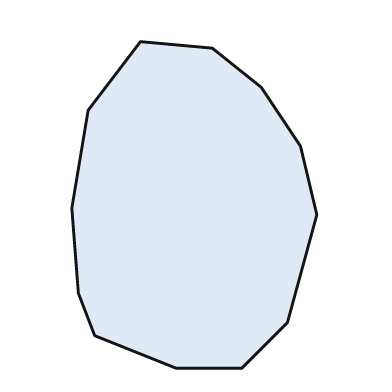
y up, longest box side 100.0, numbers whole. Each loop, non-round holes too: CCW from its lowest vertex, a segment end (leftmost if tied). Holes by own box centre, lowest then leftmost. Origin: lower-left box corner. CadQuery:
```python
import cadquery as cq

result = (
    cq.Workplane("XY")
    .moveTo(32.0, 0.0)
    .lineTo(52.0, 0.0)
    .lineTo(66.0, 14.0)
    .lineTo(75.0, 47.0)
    .lineTo(70.0, 68.0)
    .lineTo(58.0, 86.0)
    .lineTo(43.0, 98.0)
    .lineTo(21.0, 100.0)
    .lineTo(5.0, 79.0)
    .lineTo(0.0, 49.0)
    .lineTo(2.0, 23.0)
    .lineTo(7.0, 10.0)
    .close()
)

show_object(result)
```